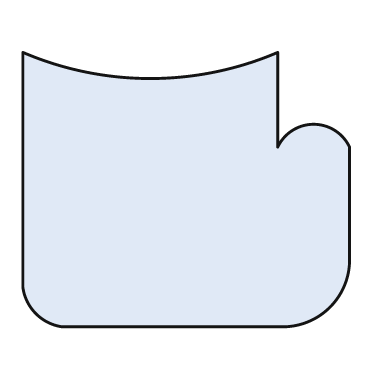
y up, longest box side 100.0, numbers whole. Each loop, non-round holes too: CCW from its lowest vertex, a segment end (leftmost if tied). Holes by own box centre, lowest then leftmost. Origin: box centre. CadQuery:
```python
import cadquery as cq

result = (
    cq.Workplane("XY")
    .moveTo(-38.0, -42.0)
    .lineTo(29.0, -42.0)
    .threePointArc((44.0, -36.0), (50.0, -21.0))
    .lineTo(50.0, 13.0)
    .threePointArc((39.0, 20.0), (28.0, 13.0))
    .lineTo(28.0, 42.0)
    .threePointArc((-11.0, 34.0), (-50.0, 42.0))
    .lineTo(-50.0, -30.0)
    .threePointArc((-46.0, -38.0), (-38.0, -42.0))
    .close()
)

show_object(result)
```